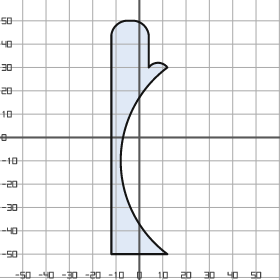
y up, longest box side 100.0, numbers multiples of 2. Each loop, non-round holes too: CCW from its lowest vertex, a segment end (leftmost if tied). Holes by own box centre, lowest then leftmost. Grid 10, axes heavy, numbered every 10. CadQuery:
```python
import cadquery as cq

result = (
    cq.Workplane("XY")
    .moveTo(-12.0, -50.0)
    .lineTo(12.0, -50.0)
    .threePointArc((-8.0, -10.0), (12.0, 30.0))
    .threePointArc((8.0, 32.0), (4.0, 30.0))
    .lineTo(4.0, 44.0)
    .threePointArc((2.0, 48.0), (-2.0, 50.0))
    .lineTo(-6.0, 50.0)
    .threePointArc((-10.0, 48.0), (-12.0, 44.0))
    .close()
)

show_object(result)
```